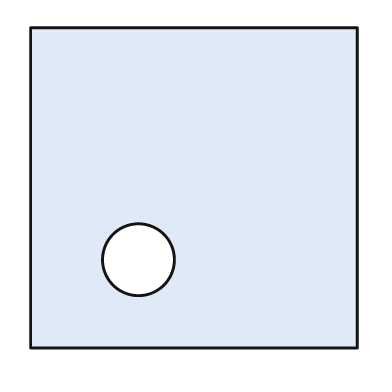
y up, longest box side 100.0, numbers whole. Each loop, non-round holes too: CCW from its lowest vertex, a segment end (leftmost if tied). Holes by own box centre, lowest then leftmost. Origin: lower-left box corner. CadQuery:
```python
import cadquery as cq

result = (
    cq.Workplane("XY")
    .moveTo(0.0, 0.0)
    .lineTo(100.0, 0.0)
    .lineTo(100.0, 98.0)
    .lineTo(0.0, 98.0)
    .close()
    .moveTo(33.0, 27.0)
    .circle(11.0)
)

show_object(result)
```